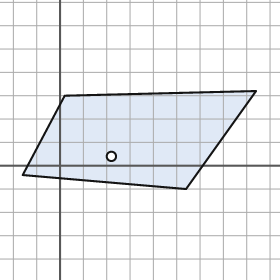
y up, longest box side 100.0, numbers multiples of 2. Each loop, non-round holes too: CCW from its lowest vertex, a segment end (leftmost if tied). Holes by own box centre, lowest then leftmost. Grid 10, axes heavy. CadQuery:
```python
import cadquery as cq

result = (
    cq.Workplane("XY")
    .moveTo(54.0, -10.0)
    .lineTo(84.0, 32.0)
    .lineTo(2.0, 30.0)
    .lineTo(-16.0, -4.0)
    .close()
    .moveTo(22.0, 4.0)
    .circle(2.0)
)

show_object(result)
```